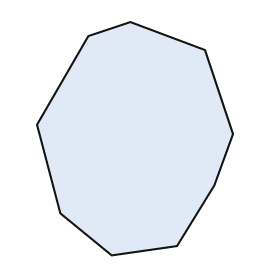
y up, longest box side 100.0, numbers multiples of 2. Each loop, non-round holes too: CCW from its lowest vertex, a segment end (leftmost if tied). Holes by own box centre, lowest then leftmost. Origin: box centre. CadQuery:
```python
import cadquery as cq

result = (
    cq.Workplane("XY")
    .moveTo(-10.0, -50.0)
    .lineTo(18.0, -46.0)
    .lineTo(34.0, -20.0)
    .lineTo(42.0, 2.0)
    .lineTo(30.0, 38.0)
    .lineTo(-2.0, 50.0)
    .lineTo(-20.0, 44.0)
    .lineTo(-42.0, 6.0)
    .lineTo(-32.0, -32.0)
    .close()
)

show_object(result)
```